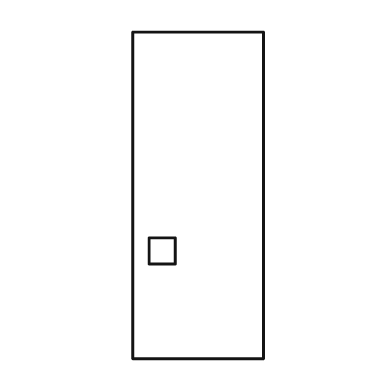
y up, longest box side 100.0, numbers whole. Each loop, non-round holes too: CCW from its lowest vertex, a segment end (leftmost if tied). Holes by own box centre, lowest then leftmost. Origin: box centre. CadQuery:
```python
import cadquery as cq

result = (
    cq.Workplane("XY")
    .moveTo(-20.0, -50.0)
    .lineTo(20.0, -50.0)
    .lineTo(20.0, 50.0)
    .lineTo(-20.0, 50.0)
    .close()
    .moveTo(-15.0, -21.0)
    .lineTo(-7.0, -21.0)
    .lineTo(-7.0, -13.0)
    .lineTo(-15.0, -13.0)
    .close()
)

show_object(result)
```